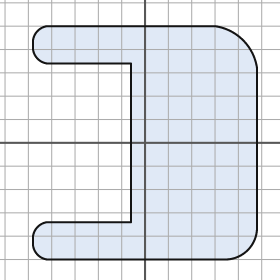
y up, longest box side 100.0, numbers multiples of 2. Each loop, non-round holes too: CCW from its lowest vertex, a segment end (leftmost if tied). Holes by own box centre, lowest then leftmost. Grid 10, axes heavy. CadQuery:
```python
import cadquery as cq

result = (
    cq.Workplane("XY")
    .moveTo(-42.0, -50.0)
    .lineTo(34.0, -50.0)
    .threePointArc((44.0, -46.0), (48.0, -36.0))
    .lineTo(48.0, 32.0)
    .threePointArc((42.0, 44.0), (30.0, 50.0))
    .lineTo(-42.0, 50.0)
    .threePointArc((-46.0, 48.0), (-48.0, 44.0))
    .lineTo(-48.0, 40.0)
    .threePointArc((-46.0, 36.0), (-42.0, 34.0))
    .lineTo(-6.0, 34.0)
    .lineTo(-6.0, -34.0)
    .lineTo(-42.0, -34.0)
    .threePointArc((-46.0, -36.0), (-48.0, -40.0))
    .lineTo(-48.0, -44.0)
    .threePointArc((-46.0, -48.0), (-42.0, -50.0))
    .close()
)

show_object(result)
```